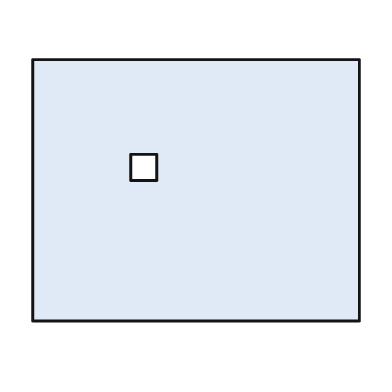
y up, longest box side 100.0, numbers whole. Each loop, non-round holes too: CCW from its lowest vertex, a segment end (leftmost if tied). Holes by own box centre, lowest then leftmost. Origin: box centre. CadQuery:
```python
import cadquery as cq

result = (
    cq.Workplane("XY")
    .moveTo(-50.0, -40.0)
    .lineTo(50.0, -40.0)
    .lineTo(50.0, 40.0)
    .lineTo(-50.0, 40.0)
    .close()
    .moveTo(-20.0, 3.0)
    .lineTo(-12.0, 3.0)
    .lineTo(-12.0, 11.0)
    .lineTo(-20.0, 11.0)
    .close()
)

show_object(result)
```